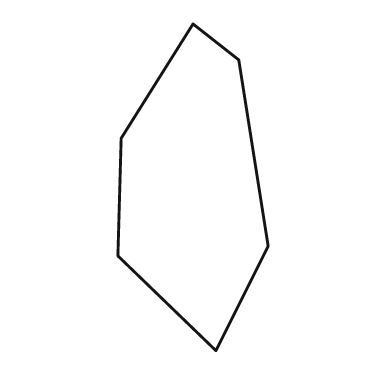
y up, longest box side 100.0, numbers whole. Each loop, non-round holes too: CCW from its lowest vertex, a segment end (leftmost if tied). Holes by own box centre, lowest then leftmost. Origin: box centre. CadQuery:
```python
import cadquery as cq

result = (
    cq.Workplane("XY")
    .moveTo(7.0, -50.0)
    .lineTo(23.0, -18.0)
    .lineTo(14.0, 39.0)
    .lineTo(0.0, 50.0)
    .lineTo(-22.0, 15.0)
    .lineTo(-23.0, -21.0)
    .close()
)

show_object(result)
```